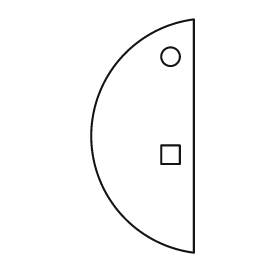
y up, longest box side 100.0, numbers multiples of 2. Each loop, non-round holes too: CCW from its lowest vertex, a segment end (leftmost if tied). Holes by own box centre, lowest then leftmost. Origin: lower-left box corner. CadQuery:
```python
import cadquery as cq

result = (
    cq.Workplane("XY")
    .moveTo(44.0, 0.0)
    .lineTo(44.0, 100.0)
    .threePointArc((0.0, 50.0), (44.0, 0.0))
    .close()
    .moveTo(30.0, 38.0)
    .lineTo(38.0, 38.0)
    .lineTo(38.0, 46.0)
    .lineTo(30.0, 46.0)
    .close()
    .moveTo(34.0, 84.0)
    .circle(4.0)
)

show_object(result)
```